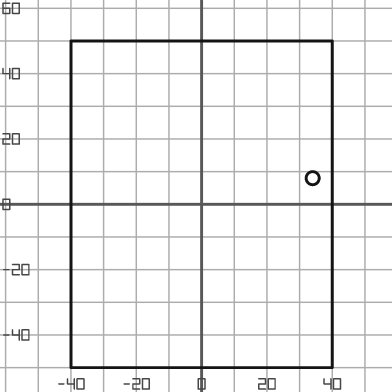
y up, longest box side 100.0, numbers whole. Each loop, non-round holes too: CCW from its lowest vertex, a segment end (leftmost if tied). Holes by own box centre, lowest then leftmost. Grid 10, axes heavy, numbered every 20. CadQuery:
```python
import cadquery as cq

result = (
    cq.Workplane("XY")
    .moveTo(-40.0, -50.0)
    .lineTo(40.0, -50.0)
    .lineTo(40.0, 50.0)
    .lineTo(-40.0, 50.0)
    .close()
    .moveTo(34.0, 8.0)
    .circle(2.0)
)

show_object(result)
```